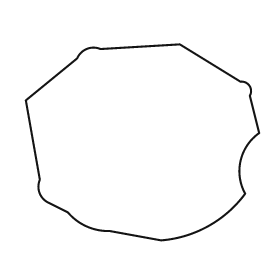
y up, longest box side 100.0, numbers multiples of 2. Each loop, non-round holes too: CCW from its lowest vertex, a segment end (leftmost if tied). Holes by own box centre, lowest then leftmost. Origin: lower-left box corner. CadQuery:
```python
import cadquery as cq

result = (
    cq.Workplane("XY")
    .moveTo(58.0, 0.0)
    .threePointArc((78.0, 6.0), (94.0, 20.0))
    .threePointArc((92.0, 34.0), (100.0, 46.0))
    .lineTo(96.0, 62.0)
    .threePointArc((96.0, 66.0), (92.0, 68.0))
    .lineTo(66.0, 84.0)
    .lineTo(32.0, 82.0)
    .threePointArc((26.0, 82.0), (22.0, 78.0))
    .lineTo(0.0, 60.0)
    .lineTo(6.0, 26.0)
    .threePointArc((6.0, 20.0), (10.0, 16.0))
    .lineTo(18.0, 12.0)
    .threePointArc((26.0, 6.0), (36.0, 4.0))
    .close()
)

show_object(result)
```